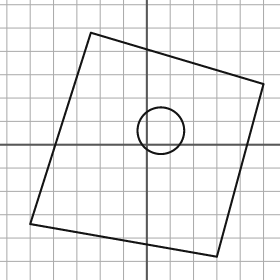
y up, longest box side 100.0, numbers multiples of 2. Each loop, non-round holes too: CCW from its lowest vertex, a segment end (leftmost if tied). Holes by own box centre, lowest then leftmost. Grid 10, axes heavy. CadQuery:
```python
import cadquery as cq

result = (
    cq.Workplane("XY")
    .moveTo(30.0, -48.0)
    .lineTo(50.0, 26.0)
    .lineTo(-24.0, 48.0)
    .lineTo(-50.0, -34.0)
    .close()
    .moveTo(6.0, 6.0)
    .circle(10.0)
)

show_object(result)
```